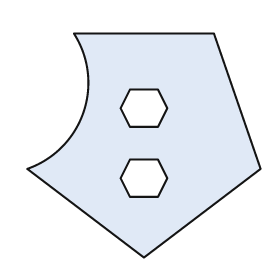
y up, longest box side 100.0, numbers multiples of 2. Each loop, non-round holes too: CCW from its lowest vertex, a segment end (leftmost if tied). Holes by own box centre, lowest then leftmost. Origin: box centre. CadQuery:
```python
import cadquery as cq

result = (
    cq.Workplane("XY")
    .moveTo(0.0, -48.0)
    .lineTo(50.0, -10.0)
    .lineTo(30.0, 48.0)
    .lineTo(-30.0, 48.0)
    .threePointArc((-26.0, 14.0), (-50.0, -10.0))
    .close()
    .moveTo(-6.0, -22.0)
    .lineTo(6.0, -22.0)
    .lineTo(10.0, -14.0)
    .lineTo(6.0, -6.0)
    .lineTo(-6.0, -6.0)
    .lineTo(-10.0, -14.0)
    .close()
    .moveTo(-6.0, 8.0)
    .lineTo(6.0, 8.0)
    .lineTo(10.0, 16.0)
    .lineTo(6.0, 24.0)
    .lineTo(-6.0, 24.0)
    .lineTo(-10.0, 16.0)
    .close()
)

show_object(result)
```